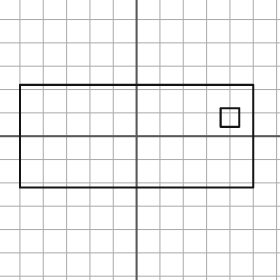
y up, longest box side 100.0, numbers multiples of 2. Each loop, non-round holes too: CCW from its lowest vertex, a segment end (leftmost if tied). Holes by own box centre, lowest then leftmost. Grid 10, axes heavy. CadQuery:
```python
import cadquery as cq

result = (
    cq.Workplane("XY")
    .moveTo(-50.0, -22.0)
    .lineTo(50.0, -22.0)
    .lineTo(50.0, 22.0)
    .lineTo(-50.0, 22.0)
    .close()
    .moveTo(36.0, 4.0)
    .lineTo(44.0, 4.0)
    .lineTo(44.0, 12.0)
    .lineTo(36.0, 12.0)
    .close()
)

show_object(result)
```